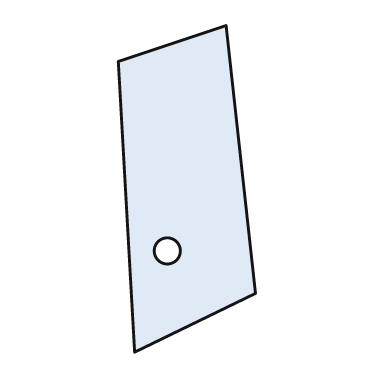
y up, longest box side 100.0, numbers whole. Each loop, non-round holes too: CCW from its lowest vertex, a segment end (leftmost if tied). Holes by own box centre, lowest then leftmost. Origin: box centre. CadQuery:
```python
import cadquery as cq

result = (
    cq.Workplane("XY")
    .moveTo(-16.0, -50.0)
    .lineTo(21.0, -32.0)
    .lineTo(12.0, 50.0)
    .lineTo(-21.0, 39.0)
    .close()
    .moveTo(-6.0, -19.0)
    .circle(4.0)
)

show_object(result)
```